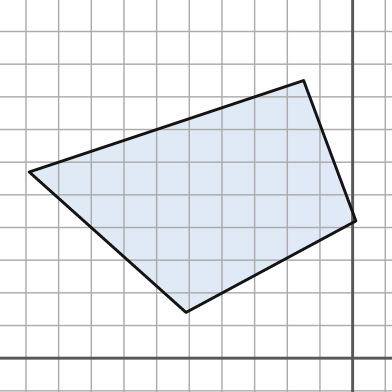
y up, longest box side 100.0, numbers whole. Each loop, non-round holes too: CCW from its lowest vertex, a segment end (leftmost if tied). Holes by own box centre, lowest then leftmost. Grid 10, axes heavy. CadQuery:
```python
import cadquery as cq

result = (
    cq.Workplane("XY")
    .moveTo(-51.0, 14.0)
    .lineTo(1.0, 42.0)
    .lineTo(-15.0, 85.0)
    .lineTo(-99.0, 57.0)
    .close()
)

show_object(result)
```